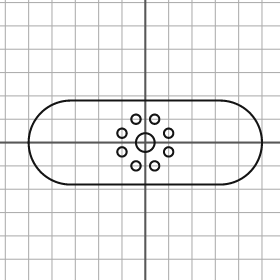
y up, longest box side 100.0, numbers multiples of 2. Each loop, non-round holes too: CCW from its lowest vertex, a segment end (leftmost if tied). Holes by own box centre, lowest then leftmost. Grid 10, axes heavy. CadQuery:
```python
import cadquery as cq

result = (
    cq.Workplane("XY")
    .moveTo(-32.0, -18.0)
    .lineTo(32.0, -18.0)
    .threePointArc((50.0, 0.0), (32.0, 18.0))
    .lineTo(-32.0, 18.0)
    .threePointArc((-50.0, 0.0), (-32.0, -18.0))
    .close()
    .moveTo(-4.0, -10.0)
    .circle(2.0)
    .moveTo(4.0, -10.0)
    .circle(2.0)
    .moveTo(-10.0, -4.0)
    .circle(2.0)
    .moveTo(10.0, -4.0)
    .circle(2.0)
    .moveTo(0.0, 0.0)
    .circle(4.0)
    .moveTo(-10.0, 4.0)
    .circle(2.0)
    .moveTo(10.0, 4.0)
    .circle(2.0)
    .moveTo(-4.0, 10.0)
    .circle(2.0)
    .moveTo(4.0, 10.0)
    .circle(2.0)
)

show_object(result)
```